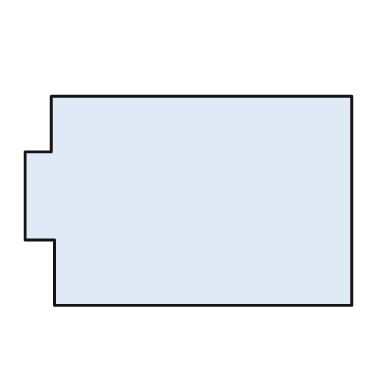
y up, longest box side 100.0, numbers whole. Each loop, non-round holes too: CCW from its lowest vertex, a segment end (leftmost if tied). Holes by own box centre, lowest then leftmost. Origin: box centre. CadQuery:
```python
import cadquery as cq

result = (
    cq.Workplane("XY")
    .moveTo(-41.0, -32.0)
    .lineTo(50.0, -32.0)
    .lineTo(50.0, 32.0)
    .lineTo(-42.0, 32.0)
    .lineTo(-42.0, 15.0)
    .lineTo(-50.0, 15.0)
    .lineTo(-50.0, -12.0)
    .lineTo(-41.0, -12.0)
    .close()
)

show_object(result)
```